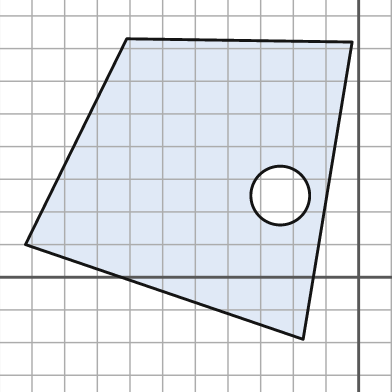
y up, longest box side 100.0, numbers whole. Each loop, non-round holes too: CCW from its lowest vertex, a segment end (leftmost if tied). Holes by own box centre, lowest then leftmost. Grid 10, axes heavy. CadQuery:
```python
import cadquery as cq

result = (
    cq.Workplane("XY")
    .moveTo(-17.0, -19.0)
    .lineTo(-2.0, 72.0)
    .lineTo(-71.0, 73.0)
    .lineTo(-102.0, 10.0)
    .close()
    .moveTo(-24.0, 25.0)
    .circle(9.0)
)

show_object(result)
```